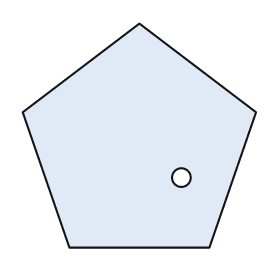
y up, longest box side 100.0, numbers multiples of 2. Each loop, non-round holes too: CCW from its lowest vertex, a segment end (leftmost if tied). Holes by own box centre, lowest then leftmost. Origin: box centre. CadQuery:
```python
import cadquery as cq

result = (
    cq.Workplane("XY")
    .moveTo(-30.0, -48.0)
    .lineTo(30.0, -48.0)
    .lineTo(50.0, 10.0)
    .lineTo(0.0, 48.0)
    .lineTo(-50.0, 10.0)
    .close()
    .moveTo(18.0, -18.0)
    .circle(4.0)
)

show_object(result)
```